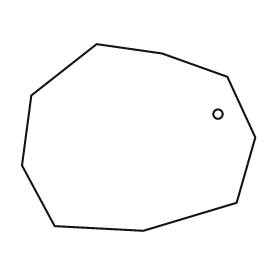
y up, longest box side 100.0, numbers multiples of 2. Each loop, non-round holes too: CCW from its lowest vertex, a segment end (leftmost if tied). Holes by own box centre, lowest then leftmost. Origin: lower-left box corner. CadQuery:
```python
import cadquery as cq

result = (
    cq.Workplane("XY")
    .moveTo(52.0, 0.0)
    .lineTo(92.0, 12.0)
    .lineTo(100.0, 40.0)
    .lineTo(88.0, 66.0)
    .lineTo(60.0, 76.0)
    .lineTo(32.0, 80.0)
    .lineTo(4.0, 58.0)
    .lineTo(0.0, 28.0)
    .lineTo(14.0, 2.0)
    .close()
    .moveTo(84.0, 50.0)
    .circle(2.0)
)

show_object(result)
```